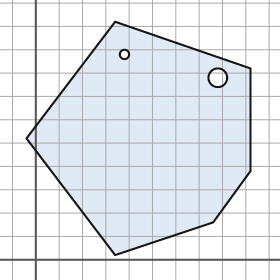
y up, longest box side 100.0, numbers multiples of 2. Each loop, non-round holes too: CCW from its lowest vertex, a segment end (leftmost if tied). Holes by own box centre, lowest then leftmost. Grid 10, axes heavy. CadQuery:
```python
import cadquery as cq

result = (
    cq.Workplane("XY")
    .moveTo(34.0, 2.0)
    .lineTo(76.0, 16.0)
    .lineTo(92.0, 38.0)
    .lineTo(92.0, 82.0)
    .lineTo(34.0, 102.0)
    .lineTo(-4.0, 52.0)
    .close()
    .moveTo(78.0, 78.0)
    .circle(4.0)
    .moveTo(38.0, 88.0)
    .circle(2.0)
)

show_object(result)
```